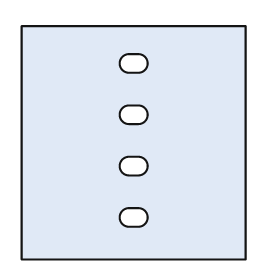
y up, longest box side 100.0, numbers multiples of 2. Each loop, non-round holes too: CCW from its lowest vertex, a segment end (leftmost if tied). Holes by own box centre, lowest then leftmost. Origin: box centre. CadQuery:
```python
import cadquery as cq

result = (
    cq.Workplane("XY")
    .moveTo(-48.0, -50.0)
    .lineTo(48.0, -50.0)
    .lineTo(48.0, 50.0)
    .lineTo(-48.0, 50.0)
    .close()
    .moveTo(-2.0, -36.0)
    .lineTo(2.0, -36.0)
    .threePointArc((6.0, -32.0), (2.0, -28.0))
    .lineTo(-2.0, -28.0)
    .threePointArc((-6.0, -32.0), (-2.0, -36.0))
    .close()
    .moveTo(-2.0, -14.0)
    .lineTo(2.0, -14.0)
    .threePointArc((6.0, -10.0), (2.0, -6.0))
    .lineTo(-2.0, -6.0)
    .threePointArc((-6.0, -10.0), (-2.0, -14.0))
    .close()
    .moveTo(-2.0, 8.0)
    .lineTo(2.0, 8.0)
    .threePointArc((6.0, 12.0), (2.0, 16.0))
    .lineTo(-2.0, 16.0)
    .threePointArc((-6.0, 12.0), (-2.0, 8.0))
    .close()
    .moveTo(-2.0, 30.0)
    .lineTo(2.0, 30.0)
    .threePointArc((6.0, 34.0), (2.0, 38.0))
    .lineTo(-2.0, 38.0)
    .threePointArc((-6.0, 34.0), (-2.0, 30.0))
    .close()
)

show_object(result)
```